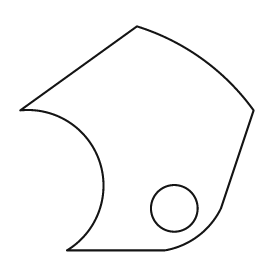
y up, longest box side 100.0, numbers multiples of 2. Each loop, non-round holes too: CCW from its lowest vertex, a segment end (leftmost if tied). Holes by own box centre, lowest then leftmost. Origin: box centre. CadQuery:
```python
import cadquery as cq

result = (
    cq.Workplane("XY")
    .moveTo(-30.0, -48.0)
    .lineTo(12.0, -48.0)
    .threePointArc((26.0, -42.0), (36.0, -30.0))
    .lineTo(50.0, 12.0)
    .threePointArc((28.0, 34.0), (0.0, 48.0))
    .lineTo(-50.0, 12.0)
    .threePointArc((-16.0, -10.0), (-30.0, -48.0))
    .close()
    .moveTo(16.0, -30.0)
    .circle(10.0)
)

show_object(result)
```